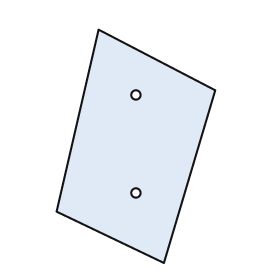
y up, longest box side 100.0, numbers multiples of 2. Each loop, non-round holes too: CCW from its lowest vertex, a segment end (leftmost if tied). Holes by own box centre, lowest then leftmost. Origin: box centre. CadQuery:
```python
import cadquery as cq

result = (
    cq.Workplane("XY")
    .moveTo(12.0, -50.0)
    .lineTo(34.0, 24.0)
    .lineTo(-16.0, 50.0)
    .lineTo(-34.0, -28.0)
    .close()
    .moveTo(0.0, -20.0)
    .circle(2.0)
    .moveTo(0.0, 22.0)
    .circle(2.0)
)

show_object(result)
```